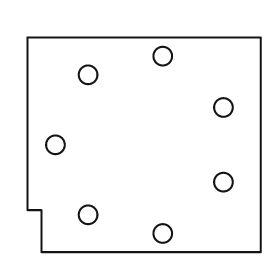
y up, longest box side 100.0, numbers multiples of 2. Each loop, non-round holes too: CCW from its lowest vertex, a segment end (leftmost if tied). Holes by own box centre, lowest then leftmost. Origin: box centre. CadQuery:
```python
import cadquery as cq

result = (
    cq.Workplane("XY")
    .moveTo(-44.0, -46.0)
    .lineTo(50.0, -46.0)
    .lineTo(50.0, 46.0)
    .lineTo(-50.0, 46.0)
    .lineTo(-50.0, -28.0)
    .lineTo(-44.0, -28.0)
    .close()
    .moveTo(8.0, -38.0)
    .circle(4.0)
    .moveTo(-24.0, -30.0)
    .circle(4.0)
    .moveTo(34.0, -16.0)
    .circle(4.0)
    .moveTo(-38.0, 0.0)
    .circle(4.0)
    .moveTo(34.0, 16.0)
    .circle(4.0)
    .moveTo(-24.0, 30.0)
    .circle(4.0)
    .moveTo(8.0, 38.0)
    .circle(4.0)
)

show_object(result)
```